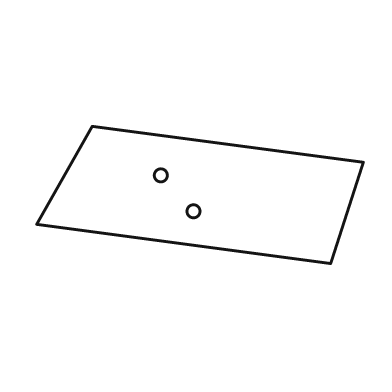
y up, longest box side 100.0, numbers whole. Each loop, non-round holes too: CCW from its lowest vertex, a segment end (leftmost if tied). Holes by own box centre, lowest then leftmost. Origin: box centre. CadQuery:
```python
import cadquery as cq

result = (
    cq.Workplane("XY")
    .moveTo(40.0, -21.0)
    .lineTo(50.0, 10.0)
    .lineTo(-33.0, 21.0)
    .lineTo(-50.0, -9.0)
    .close()
    .moveTo(-2.0, -5.0)
    .circle(2.0)
    .moveTo(-12.0, 6.0)
    .circle(2.0)
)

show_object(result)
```